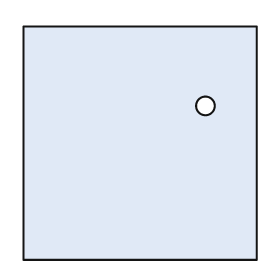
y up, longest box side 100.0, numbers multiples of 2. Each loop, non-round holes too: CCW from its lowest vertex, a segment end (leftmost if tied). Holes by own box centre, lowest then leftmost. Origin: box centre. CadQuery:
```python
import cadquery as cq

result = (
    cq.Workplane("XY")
    .moveTo(-50.0, -50.0)
    .lineTo(50.0, -50.0)
    .lineTo(50.0, 50.0)
    .lineTo(-50.0, 50.0)
    .close()
    .moveTo(28.0, 16.0)
    .circle(4.0)
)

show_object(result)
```